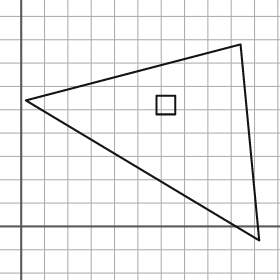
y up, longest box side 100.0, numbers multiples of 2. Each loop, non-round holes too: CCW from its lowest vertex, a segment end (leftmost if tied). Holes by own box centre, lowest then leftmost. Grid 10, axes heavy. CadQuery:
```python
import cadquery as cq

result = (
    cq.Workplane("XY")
    .moveTo(102.0, -6.0)
    .lineTo(94.0, 78.0)
    .lineTo(2.0, 54.0)
    .close()
    .moveTo(58.0, 48.0)
    .lineTo(66.0, 48.0)
    .lineTo(66.0, 56.0)
    .lineTo(58.0, 56.0)
    .close()
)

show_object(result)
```